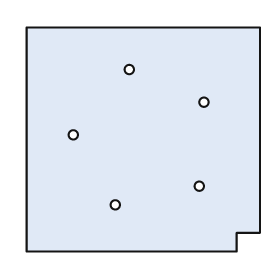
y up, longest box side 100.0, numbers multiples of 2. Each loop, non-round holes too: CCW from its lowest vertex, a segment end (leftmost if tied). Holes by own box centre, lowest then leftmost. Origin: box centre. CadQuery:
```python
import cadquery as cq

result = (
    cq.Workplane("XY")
    .moveTo(-50.0, -48.0)
    .lineTo(40.0, -48.0)
    .lineTo(40.0, -40.0)
    .lineTo(50.0, -40.0)
    .lineTo(50.0, 48.0)
    .lineTo(-50.0, 48.0)
    .close()
    .moveTo(-12.0, -28.0)
    .circle(2.0)
    .moveTo(24.0, -20.0)
    .circle(2.0)
    .moveTo(-30.0, 2.0)
    .circle(2.0)
    .moveTo(26.0, 16.0)
    .circle(2.0)
    .moveTo(-6.0, 30.0)
    .circle(2.0)
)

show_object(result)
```